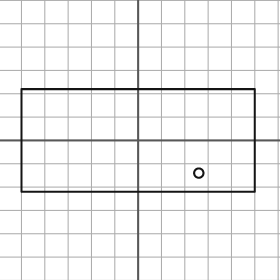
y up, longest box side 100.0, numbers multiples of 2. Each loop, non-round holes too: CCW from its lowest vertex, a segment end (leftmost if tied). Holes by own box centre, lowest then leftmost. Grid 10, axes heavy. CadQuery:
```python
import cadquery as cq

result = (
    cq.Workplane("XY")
    .moveTo(-50.0, -22.0)
    .lineTo(50.0, -22.0)
    .lineTo(50.0, 22.0)
    .lineTo(-50.0, 22.0)
    .close()
    .moveTo(26.0, -14.0)
    .circle(2.0)
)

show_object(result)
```